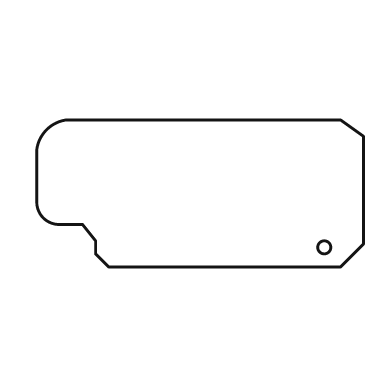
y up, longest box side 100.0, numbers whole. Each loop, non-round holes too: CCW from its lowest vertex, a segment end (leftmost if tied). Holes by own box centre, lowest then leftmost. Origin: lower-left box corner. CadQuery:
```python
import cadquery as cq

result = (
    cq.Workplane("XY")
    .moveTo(22.0, 0.0)
    .lineTo(93.0, 0.0)
    .lineTo(100.0, 7.0)
    .lineTo(100.0, 40.0)
    .lineTo(93.0, 45.0)
    .lineTo(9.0, 45.0)
    .threePointArc((3.0, 42.0), (0.0, 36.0))
    .lineTo(0.0, 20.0)
    .threePointArc((2.0, 15.0), (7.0, 13.0))
    .lineTo(14.0, 13.0)
    .lineTo(18.0, 8.0)
    .lineTo(18.0, 4.0)
    .close()
    .moveTo(88.0, 6.0)
    .circle(2.0)
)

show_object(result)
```